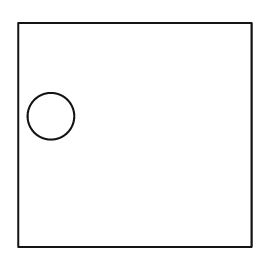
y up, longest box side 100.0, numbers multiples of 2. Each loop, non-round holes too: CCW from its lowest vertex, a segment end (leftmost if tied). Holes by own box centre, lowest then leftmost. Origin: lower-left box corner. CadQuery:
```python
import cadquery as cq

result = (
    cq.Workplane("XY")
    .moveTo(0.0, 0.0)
    .lineTo(100.0, 0.0)
    .lineTo(100.0, 96.0)
    .lineTo(0.0, 96.0)
    .close()
    .moveTo(14.0, 56.0)
    .circle(10.0)
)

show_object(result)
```